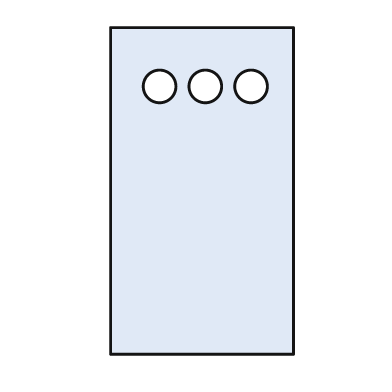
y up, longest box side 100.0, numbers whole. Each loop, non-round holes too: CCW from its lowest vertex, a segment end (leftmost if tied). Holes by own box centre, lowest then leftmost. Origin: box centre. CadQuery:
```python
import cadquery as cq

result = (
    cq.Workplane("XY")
    .moveTo(-28.0, -50.0)
    .lineTo(28.0, -50.0)
    .lineTo(28.0, 50.0)
    .lineTo(-28.0, 50.0)
    .close()
    .moveTo(-13.0, 32.0)
    .circle(5.0)
    .moveTo(1.0, 32.0)
    .circle(5.0)
    .moveTo(15.0, 32.0)
    .circle(5.0)
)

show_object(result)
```